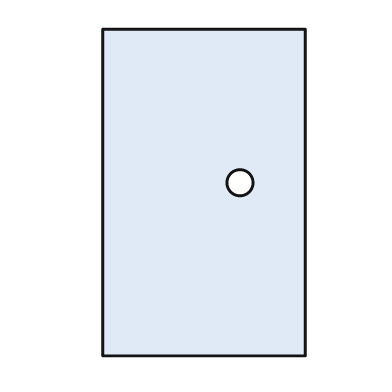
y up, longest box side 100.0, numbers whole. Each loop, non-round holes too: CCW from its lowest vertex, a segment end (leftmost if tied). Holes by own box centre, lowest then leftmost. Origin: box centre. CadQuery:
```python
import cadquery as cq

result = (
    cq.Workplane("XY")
    .moveTo(-31.0, -50.0)
    .lineTo(31.0, -50.0)
    .lineTo(31.0, 50.0)
    .lineTo(-31.0, 50.0)
    .close()
    .moveTo(11.0, 3.0)
    .circle(4.0)
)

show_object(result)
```